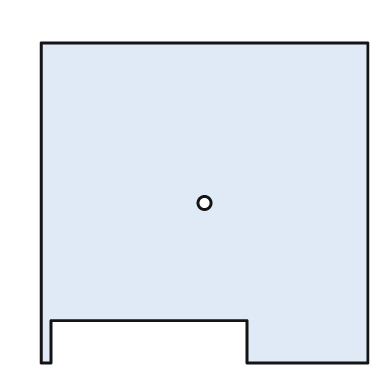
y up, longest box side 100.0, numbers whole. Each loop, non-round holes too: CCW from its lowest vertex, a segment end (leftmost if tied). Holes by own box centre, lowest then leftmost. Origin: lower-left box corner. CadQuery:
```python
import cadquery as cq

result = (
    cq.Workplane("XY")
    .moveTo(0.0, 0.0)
    .lineTo(3.0, 0.0)
    .lineTo(3.0, 13.0)
    .lineTo(63.0, 13.0)
    .lineTo(63.0, 0.0)
    .lineTo(100.0, 0.0)
    .lineTo(100.0, 98.0)
    .lineTo(0.0, 98.0)
    .close()
    .moveTo(50.0, 49.0)
    .circle(2.0)
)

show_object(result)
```